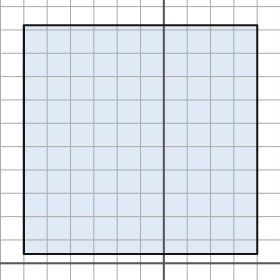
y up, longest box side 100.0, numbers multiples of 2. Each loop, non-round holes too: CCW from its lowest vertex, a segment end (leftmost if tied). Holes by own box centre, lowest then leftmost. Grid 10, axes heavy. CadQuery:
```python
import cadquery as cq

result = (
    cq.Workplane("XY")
    .moveTo(-60.0, 4.0)
    .lineTo(40.0, 4.0)
    .lineTo(40.0, 102.0)
    .lineTo(-60.0, 102.0)
    .close()
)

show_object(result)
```